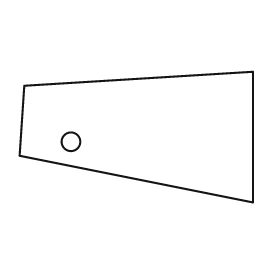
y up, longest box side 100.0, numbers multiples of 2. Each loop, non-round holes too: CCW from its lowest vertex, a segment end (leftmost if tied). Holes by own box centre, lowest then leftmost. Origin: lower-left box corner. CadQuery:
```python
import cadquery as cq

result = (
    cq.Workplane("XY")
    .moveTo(100.0, 0.0)
    .lineTo(100.0, 56.0)
    .lineTo(2.0, 50.0)
    .lineTo(0.0, 20.0)
    .close()
    .moveTo(22.0, 26.0)
    .circle(4.0)
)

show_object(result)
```